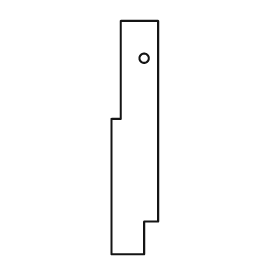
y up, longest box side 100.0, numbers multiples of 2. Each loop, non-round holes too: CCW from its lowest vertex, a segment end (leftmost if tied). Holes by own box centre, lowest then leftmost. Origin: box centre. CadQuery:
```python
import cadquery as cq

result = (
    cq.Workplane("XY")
    .moveTo(-10.0, -50.0)
    .lineTo(4.0, -50.0)
    .lineTo(4.0, -36.0)
    .lineTo(10.0, -36.0)
    .lineTo(10.0, 50.0)
    .lineTo(-6.0, 50.0)
    .lineTo(-6.0, 8.0)
    .lineTo(-10.0, 8.0)
    .close()
    .moveTo(4.0, 34.0)
    .circle(2.0)
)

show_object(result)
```